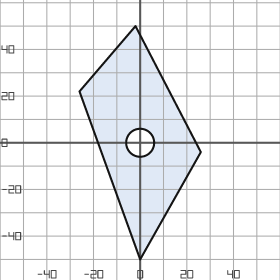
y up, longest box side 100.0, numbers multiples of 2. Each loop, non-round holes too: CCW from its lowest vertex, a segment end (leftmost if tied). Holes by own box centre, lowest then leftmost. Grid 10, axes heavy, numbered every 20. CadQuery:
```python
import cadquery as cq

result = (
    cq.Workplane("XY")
    .moveTo(0.0, -50.0)
    .lineTo(26.0, -4.0)
    .lineTo(-2.0, 50.0)
    .lineTo(-26.0, 22.0)
    .close()
    .moveTo(0.0, 0.0)
    .circle(6.0)
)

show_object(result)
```